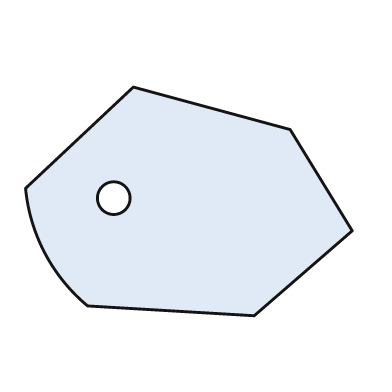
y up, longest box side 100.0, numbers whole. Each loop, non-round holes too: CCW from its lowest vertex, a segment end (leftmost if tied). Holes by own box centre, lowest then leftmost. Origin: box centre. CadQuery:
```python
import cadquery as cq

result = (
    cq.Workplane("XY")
    .moveTo(20.0, -35.0)
    .lineTo(50.0, -9.0)
    .lineTo(31.0, 22.0)
    .lineTo(-17.0, 35.0)
    .lineTo(-50.0, 4.0)
    .threePointArc((-44.0, -16.0), (-31.0, -32.0))
    .close()
    .moveTo(-23.0, 1.0)
    .circle(5.0)
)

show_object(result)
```